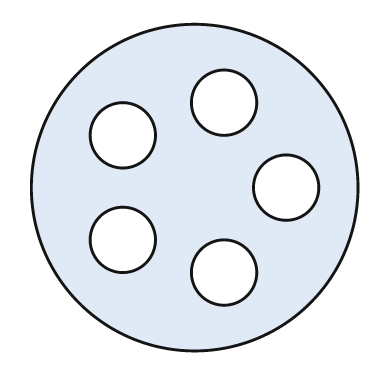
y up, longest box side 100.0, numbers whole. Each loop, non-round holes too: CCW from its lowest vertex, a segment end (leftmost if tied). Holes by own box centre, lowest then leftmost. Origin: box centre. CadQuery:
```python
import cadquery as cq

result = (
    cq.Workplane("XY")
    .moveTo(0.0, 0.0)
    .circle(50.0)
    .moveTo(9.0, -26.0)
    .circle(10.0)
    .moveTo(-22.0, -16.0)
    .circle(10.0)
    .moveTo(28.0, 0.0)
    .circle(10.0)
    .moveTo(-22.0, 16.0)
    .circle(10.0)
    .moveTo(9.0, 26.0)
    .circle(10.0)
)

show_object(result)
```